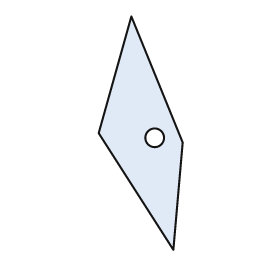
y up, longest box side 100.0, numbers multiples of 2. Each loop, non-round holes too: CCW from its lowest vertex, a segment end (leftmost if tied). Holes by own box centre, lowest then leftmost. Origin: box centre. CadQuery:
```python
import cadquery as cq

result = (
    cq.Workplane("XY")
    .moveTo(14.0, -50.0)
    .lineTo(18.0, -4.0)
    .lineTo(-4.0, 50.0)
    .lineTo(-18.0, 0.0)
    .close()
    .moveTo(6.0, -2.0)
    .circle(4.0)
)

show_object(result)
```